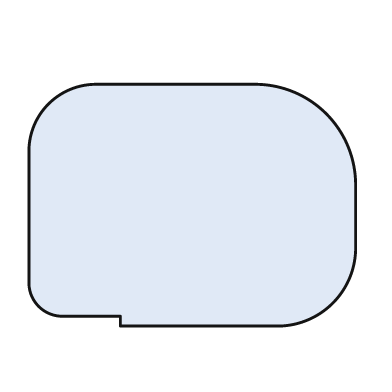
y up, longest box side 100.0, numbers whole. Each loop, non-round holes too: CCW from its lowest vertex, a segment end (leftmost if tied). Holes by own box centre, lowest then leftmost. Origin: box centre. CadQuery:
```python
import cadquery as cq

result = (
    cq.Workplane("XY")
    .moveTo(-22.0, -37.0)
    .lineTo(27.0, -37.0)
    .threePointArc((43.0, -30.0), (50.0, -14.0))
    .lineTo(50.0, 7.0)
    .threePointArc((41.0, 28.0), (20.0, 37.0))
    .lineTo(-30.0, 37.0)
    .threePointArc((-44.0, 31.0), (-50.0, 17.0))
    .lineTo(-50.0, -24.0)
    .threePointArc((-47.0, -31.0), (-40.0, -34.0))
    .lineTo(-22.0, -34.0)
    .close()
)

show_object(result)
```